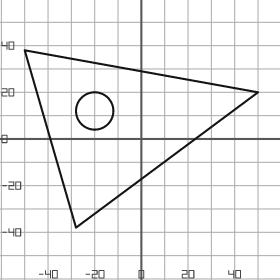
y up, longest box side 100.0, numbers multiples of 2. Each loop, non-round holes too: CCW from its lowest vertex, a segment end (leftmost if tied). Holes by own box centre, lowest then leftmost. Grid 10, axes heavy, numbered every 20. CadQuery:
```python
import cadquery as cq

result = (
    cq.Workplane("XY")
    .moveTo(-28.0, -38.0)
    .lineTo(50.0, 20.0)
    .lineTo(-50.0, 38.0)
    .close()
    .moveTo(-20.0, 12.0)
    .circle(8.0)
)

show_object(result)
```